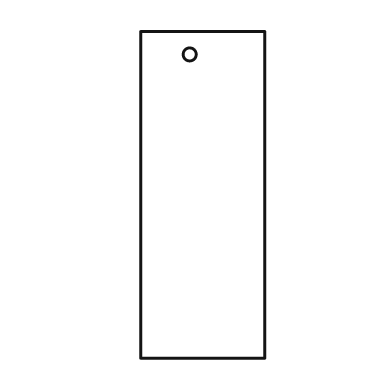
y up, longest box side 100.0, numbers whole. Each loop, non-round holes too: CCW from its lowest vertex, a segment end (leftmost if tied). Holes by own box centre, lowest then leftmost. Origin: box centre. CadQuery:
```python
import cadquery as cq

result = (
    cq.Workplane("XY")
    .moveTo(-19.0, -50.0)
    .lineTo(19.0, -50.0)
    .lineTo(19.0, 50.0)
    .lineTo(-19.0, 50.0)
    .close()
    .moveTo(-4.0, 43.0)
    .circle(2.0)
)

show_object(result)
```